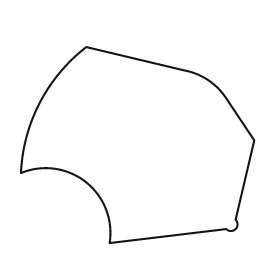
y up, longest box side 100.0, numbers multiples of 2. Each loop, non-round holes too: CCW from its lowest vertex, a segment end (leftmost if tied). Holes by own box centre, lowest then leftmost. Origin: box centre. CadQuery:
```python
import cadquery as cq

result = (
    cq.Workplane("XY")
    .moveTo(-12.0, -42.0)
    .lineTo(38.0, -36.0)
    .threePointArc((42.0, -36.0), (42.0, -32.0))
    .lineTo(50.0, 2.0)
    .lineTo(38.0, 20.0)
    .threePointArc((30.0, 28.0), (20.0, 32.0))
    .lineTo(-22.0, 42.0)
    .threePointArc((-42.0, 18.0), (-50.0, -12.0))
    .threePointArc((-22.0, -16.0), (-12.0, -42.0))
    .close()
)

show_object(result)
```